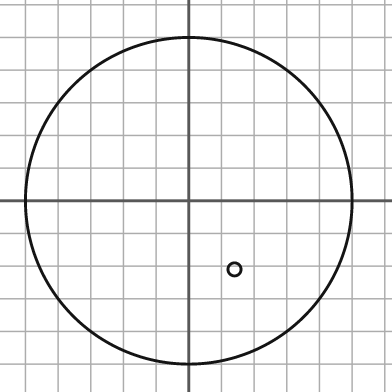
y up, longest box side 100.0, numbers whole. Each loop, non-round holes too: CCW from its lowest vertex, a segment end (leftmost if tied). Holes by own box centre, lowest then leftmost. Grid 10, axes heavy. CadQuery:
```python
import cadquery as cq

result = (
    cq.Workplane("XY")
    .moveTo(0.0, 0.0)
    .circle(50.0)
    .moveTo(14.0, -21.0)
    .circle(2.0)
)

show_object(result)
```